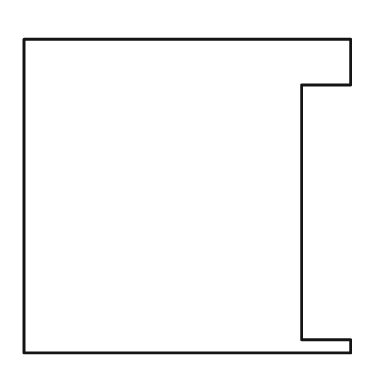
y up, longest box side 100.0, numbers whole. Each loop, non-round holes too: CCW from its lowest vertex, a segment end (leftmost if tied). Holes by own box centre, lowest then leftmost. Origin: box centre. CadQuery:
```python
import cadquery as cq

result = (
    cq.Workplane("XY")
    .moveTo(-50.0, -48.0)
    .lineTo(50.0, -48.0)
    .lineTo(50.0, -44.0)
    .lineTo(35.0, -44.0)
    .lineTo(35.0, 34.0)
    .lineTo(50.0, 34.0)
    .lineTo(50.0, 48.0)
    .lineTo(-50.0, 48.0)
    .close()
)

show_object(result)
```